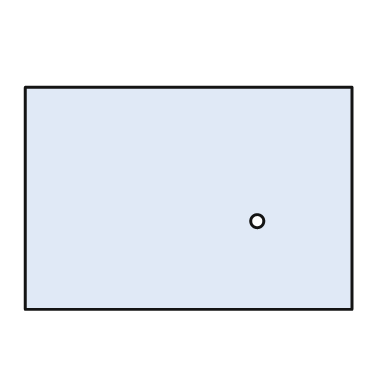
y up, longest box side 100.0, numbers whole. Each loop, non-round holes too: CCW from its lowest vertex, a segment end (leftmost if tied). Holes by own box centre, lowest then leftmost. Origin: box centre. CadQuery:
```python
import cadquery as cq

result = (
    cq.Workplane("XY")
    .moveTo(-50.0, -34.0)
    .lineTo(50.0, -34.0)
    .lineTo(50.0, 34.0)
    .lineTo(-50.0, 34.0)
    .close()
    .moveTo(21.0, -7.0)
    .circle(2.0)
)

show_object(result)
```